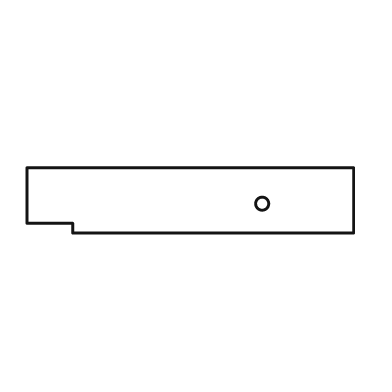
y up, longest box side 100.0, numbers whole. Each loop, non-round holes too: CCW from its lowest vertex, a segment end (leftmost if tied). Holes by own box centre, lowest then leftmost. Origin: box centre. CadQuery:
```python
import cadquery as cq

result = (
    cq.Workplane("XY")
    .moveTo(-36.0, -10.0)
    .lineTo(50.0, -10.0)
    .lineTo(50.0, 10.0)
    .lineTo(-50.0, 10.0)
    .lineTo(-50.0, -7.0)
    .lineTo(-36.0, -7.0)
    .close()
    .moveTo(22.0, -1.0)
    .circle(2.0)
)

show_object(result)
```